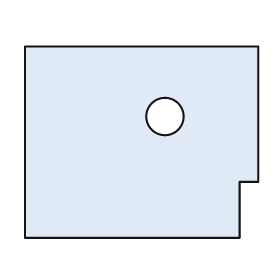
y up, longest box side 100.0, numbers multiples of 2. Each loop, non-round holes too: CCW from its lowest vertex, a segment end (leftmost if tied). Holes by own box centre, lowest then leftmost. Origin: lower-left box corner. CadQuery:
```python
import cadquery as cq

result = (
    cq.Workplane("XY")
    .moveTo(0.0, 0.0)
    .lineTo(92.0, 0.0)
    .lineTo(92.0, 24.0)
    .lineTo(100.0, 24.0)
    .lineTo(100.0, 82.0)
    .lineTo(0.0, 82.0)
    .close()
    .moveTo(60.0, 52.0)
    .circle(8.0)
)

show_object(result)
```